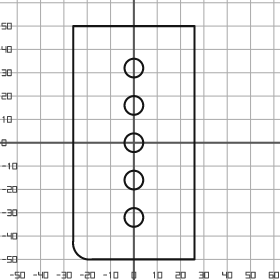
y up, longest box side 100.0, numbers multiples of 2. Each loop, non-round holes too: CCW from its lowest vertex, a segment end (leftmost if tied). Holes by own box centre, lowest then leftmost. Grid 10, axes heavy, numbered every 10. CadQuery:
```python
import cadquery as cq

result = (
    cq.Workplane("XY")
    .moveTo(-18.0, -50.0)
    .lineTo(26.0, -50.0)
    .lineTo(26.0, 50.0)
    .lineTo(-26.0, 50.0)
    .lineTo(-26.0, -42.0)
    .threePointArc((-24.0, -48.0), (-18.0, -50.0))
    .close()
    .moveTo(0.0, -32.0)
    .circle(4.0)
    .moveTo(0.0, -16.0)
    .circle(4.0)
    .moveTo(0.0, 0.0)
    .circle(4.0)
    .moveTo(0.0, 16.0)
    .circle(4.0)
    .moveTo(0.0, 32.0)
    .circle(4.0)
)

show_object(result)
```